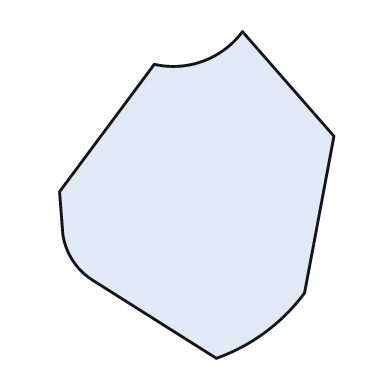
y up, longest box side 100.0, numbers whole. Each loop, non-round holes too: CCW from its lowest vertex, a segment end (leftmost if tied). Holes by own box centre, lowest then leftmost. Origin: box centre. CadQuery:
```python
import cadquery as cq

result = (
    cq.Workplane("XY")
    .moveTo(6.0, -50.0)
    .threePointArc((21.0, -42.0), (33.0, -30.0))
    .lineTo(42.0, 18.0)
    .lineTo(14.0, 50.0)
    .threePointArc((2.0, 41.0), (-13.0, 40.0))
    .lineTo(-42.0, 1.0)
    .lineTo(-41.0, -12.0)
    .threePointArc((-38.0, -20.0), (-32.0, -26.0))
    .close()
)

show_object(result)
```